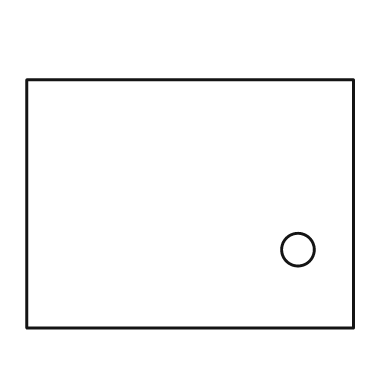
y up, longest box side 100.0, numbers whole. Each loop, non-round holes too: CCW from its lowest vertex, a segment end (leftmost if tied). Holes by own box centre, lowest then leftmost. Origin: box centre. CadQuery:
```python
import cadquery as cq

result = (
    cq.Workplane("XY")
    .moveTo(-50.0, -38.0)
    .lineTo(50.0, -38.0)
    .lineTo(50.0, 38.0)
    .lineTo(-50.0, 38.0)
    .close()
    .moveTo(33.0, -14.0)
    .circle(5.0)
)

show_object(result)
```